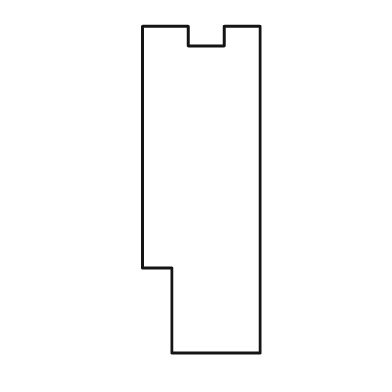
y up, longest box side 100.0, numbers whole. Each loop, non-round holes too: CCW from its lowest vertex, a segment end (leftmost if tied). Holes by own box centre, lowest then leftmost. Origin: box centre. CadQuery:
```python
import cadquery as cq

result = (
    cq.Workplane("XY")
    .moveTo(-9.0, -50.0)
    .lineTo(18.0, -50.0)
    .lineTo(18.0, 50.0)
    .lineTo(7.0, 50.0)
    .lineTo(7.0, 44.0)
    .lineTo(-4.0, 44.0)
    .lineTo(-4.0, 50.0)
    .lineTo(-18.0, 50.0)
    .lineTo(-18.0, -24.0)
    .lineTo(-9.0, -24.0)
    .close()
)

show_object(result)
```